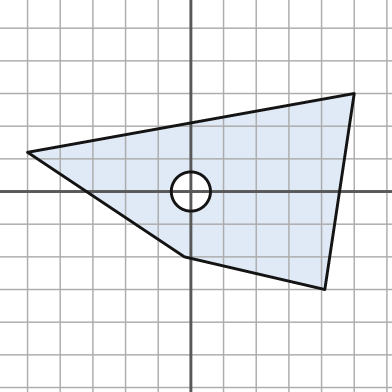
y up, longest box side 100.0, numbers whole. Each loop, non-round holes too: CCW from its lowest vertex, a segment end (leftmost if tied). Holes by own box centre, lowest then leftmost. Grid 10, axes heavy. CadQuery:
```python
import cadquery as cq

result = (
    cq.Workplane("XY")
    .moveTo(41.0, -30.0)
    .lineTo(50.0, 30.0)
    .lineTo(-50.0, 12.0)
    .lineTo(-2.0, -20.0)
    .close()
    .moveTo(0.0, 0.0)
    .circle(6.0)
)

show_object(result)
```